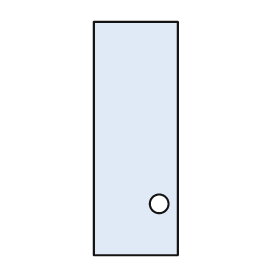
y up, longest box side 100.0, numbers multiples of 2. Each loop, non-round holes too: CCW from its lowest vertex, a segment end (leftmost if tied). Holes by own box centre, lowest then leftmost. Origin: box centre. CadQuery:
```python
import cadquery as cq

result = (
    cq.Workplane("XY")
    .moveTo(-18.0, -50.0)
    .lineTo(18.0, -50.0)
    .lineTo(18.0, 50.0)
    .lineTo(-18.0, 50.0)
    .close()
    .moveTo(10.0, -28.0)
    .circle(4.0)
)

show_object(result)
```